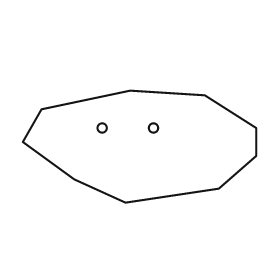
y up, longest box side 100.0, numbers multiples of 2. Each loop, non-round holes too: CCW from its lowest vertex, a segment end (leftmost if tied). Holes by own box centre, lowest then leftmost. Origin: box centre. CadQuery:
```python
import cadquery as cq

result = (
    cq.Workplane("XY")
    .moveTo(-6.0, -24.0)
    .lineTo(34.0, -18.0)
    .lineTo(50.0, -4.0)
    .lineTo(50.0, 8.0)
    .lineTo(28.0, 22.0)
    .lineTo(-4.0, 24.0)
    .lineTo(-42.0, 16.0)
    .lineTo(-50.0, 2.0)
    .lineTo(-28.0, -14.0)
    .close()
    .moveTo(-16.0, 8.0)
    .circle(2.0)
    .moveTo(6.0, 8.0)
    .circle(2.0)
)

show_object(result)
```